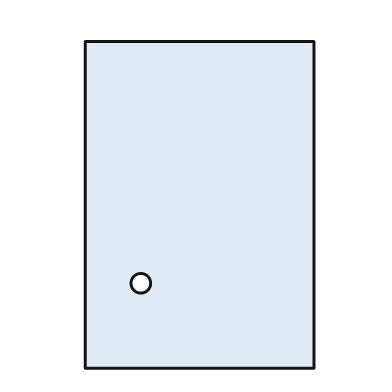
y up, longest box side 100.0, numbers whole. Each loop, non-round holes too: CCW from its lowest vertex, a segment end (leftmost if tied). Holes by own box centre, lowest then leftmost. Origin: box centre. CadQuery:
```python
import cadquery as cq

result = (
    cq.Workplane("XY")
    .moveTo(-35.0, -50.0)
    .lineTo(35.0, -50.0)
    .lineTo(35.0, 50.0)
    .lineTo(-35.0, 50.0)
    .close()
    .moveTo(-18.0, -24.0)
    .circle(3.0)
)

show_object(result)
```